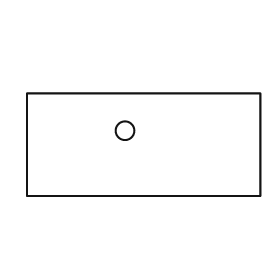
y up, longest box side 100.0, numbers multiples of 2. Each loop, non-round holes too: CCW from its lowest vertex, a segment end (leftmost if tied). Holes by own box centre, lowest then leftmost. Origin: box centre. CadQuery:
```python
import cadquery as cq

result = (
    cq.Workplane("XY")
    .moveTo(-50.0, -22.0)
    .lineTo(50.0, -22.0)
    .lineTo(50.0, 22.0)
    .lineTo(-50.0, 22.0)
    .close()
    .moveTo(-8.0, 6.0)
    .circle(4.0)
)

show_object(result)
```